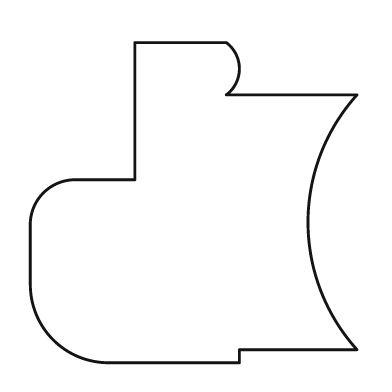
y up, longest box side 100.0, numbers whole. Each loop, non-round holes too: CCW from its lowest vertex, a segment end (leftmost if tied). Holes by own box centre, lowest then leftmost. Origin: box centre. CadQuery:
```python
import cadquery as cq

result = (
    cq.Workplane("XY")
    .moveTo(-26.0, -49.0)
    .lineTo(14.0, -49.0)
    .lineTo(14.0, -45.0)
    .lineTo(50.0, -45.0)
    .threePointArc((35.0, -6.0), (50.0, 33.0))
    .lineTo(10.0, 33.0)
    .threePointArc((14.0, 41.0), (10.0, 49.0))
    .lineTo(-18.0, 49.0)
    .lineTo(-18.0, 7.0)
    .lineTo(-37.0, 7.0)
    .threePointArc((-46.0, 3.0), (-50.0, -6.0))
    .lineTo(-50.0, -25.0)
    .threePointArc((-43.0, -42.0), (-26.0, -49.0))
    .close()
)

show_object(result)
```